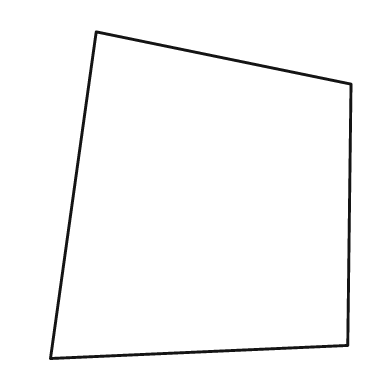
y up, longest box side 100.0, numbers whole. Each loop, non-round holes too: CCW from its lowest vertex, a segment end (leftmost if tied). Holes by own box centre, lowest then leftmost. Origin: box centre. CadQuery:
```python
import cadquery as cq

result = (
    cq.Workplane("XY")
    .moveTo(-46.0, -50.0)
    .lineTo(45.0, -46.0)
    .lineTo(46.0, 34.0)
    .lineTo(-32.0, 50.0)
    .close()
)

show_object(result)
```